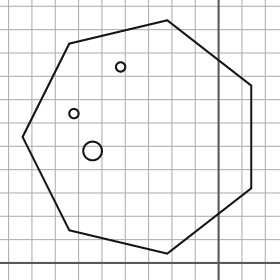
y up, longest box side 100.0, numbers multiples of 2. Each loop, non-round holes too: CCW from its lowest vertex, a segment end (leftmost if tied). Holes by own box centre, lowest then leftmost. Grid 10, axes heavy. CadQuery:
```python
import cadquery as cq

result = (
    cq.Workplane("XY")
    .moveTo(-22.0, 4.0)
    .lineTo(14.0, 32.0)
    .lineTo(14.0, 76.0)
    .lineTo(-22.0, 104.0)
    .lineTo(-64.0, 94.0)
    .lineTo(-84.0, 54.0)
    .lineTo(-64.0, 14.0)
    .close()
    .moveTo(-54.0, 48.0)
    .circle(4.0)
    .moveTo(-62.0, 64.0)
    .circle(2.0)
    .moveTo(-42.0, 84.0)
    .circle(2.0)
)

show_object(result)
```